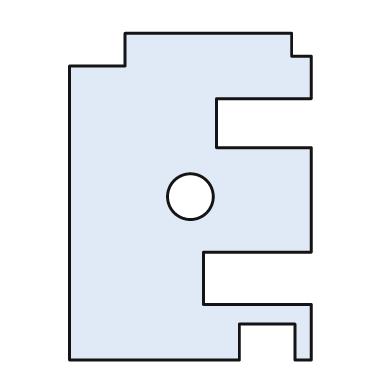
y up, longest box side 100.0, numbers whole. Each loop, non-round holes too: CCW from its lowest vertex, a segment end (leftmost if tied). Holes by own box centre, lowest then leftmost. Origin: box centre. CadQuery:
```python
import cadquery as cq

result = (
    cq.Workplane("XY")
    .moveTo(-37.0, -50.0)
    .lineTo(15.0, -50.0)
    .lineTo(15.0, -39.0)
    .lineTo(32.0, -39.0)
    .lineTo(32.0, -50.0)
    .lineTo(37.0, -50.0)
    .lineTo(37.0, -33.0)
    .lineTo(4.0, -33.0)
    .lineTo(4.0, -17.0)
    .lineTo(37.0, -17.0)
    .lineTo(37.0, 15.0)
    .lineTo(8.0, 15.0)
    .lineTo(8.0, 30.0)
    .lineTo(37.0, 30.0)
    .lineTo(37.0, 43.0)
    .lineTo(31.0, 43.0)
    .lineTo(31.0, 50.0)
    .lineTo(-20.0, 50.0)
    .lineTo(-20.0, 40.0)
    .lineTo(-37.0, 40.0)
    .close()
    .moveTo(0.0, 0.0)
    .circle(7.0)
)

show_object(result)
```